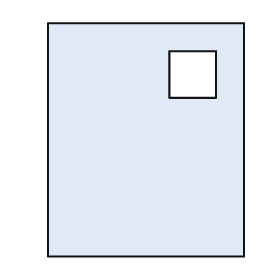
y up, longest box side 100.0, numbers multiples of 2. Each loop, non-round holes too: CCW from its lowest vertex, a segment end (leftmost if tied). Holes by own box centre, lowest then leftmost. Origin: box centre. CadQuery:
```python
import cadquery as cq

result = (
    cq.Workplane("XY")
    .moveTo(-42.0, -50.0)
    .lineTo(42.0, -50.0)
    .lineTo(42.0, 50.0)
    .lineTo(-42.0, 50.0)
    .close()
    .moveTo(10.0, 18.0)
    .lineTo(30.0, 18.0)
    .lineTo(30.0, 38.0)
    .lineTo(10.0, 38.0)
    .close()
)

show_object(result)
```